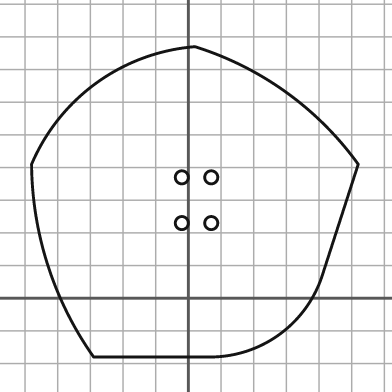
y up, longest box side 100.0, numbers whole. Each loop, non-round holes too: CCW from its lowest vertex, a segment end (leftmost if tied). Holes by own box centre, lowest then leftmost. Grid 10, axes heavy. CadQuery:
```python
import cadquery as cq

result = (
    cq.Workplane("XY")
    .moveTo(-29.0, -18.0)
    .lineTo(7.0, -18.0)
    .threePointArc((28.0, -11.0), (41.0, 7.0))
    .lineTo(52.0, 41.0)
    .threePointArc((30.0, 63.0), (2.0, 77.0))
    .threePointArc((-28.0, 66.0), (-48.0, 41.0))
    .threePointArc((-43.0, 10.0), (-29.0, -18.0))
    .close()
    .moveTo(-2.0, 23.0)
    .circle(2.0)
    .moveTo(7.0, 23.0)
    .circle(2.0)
    .moveTo(-2.0, 37.0)
    .circle(2.0)
    .moveTo(7.0, 37.0)
    .circle(2.0)
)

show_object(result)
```